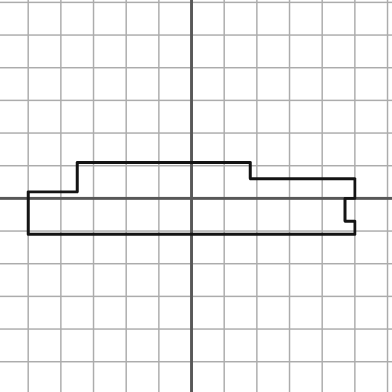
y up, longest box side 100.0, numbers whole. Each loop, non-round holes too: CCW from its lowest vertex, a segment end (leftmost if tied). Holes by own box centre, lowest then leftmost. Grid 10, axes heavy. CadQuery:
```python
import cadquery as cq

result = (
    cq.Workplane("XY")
    .moveTo(-50.0, -11.0)
    .lineTo(50.0, -11.0)
    .lineTo(50.0, -7.0)
    .lineTo(47.0, -7.0)
    .lineTo(47.0, 0.0)
    .lineTo(50.0, 0.0)
    .lineTo(50.0, 6.0)
    .lineTo(18.0, 6.0)
    .lineTo(18.0, 11.0)
    .lineTo(-35.0, 11.0)
    .lineTo(-35.0, 2.0)
    .lineTo(-50.0, 2.0)
    .close()
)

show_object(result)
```